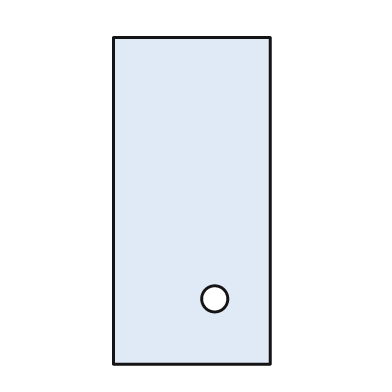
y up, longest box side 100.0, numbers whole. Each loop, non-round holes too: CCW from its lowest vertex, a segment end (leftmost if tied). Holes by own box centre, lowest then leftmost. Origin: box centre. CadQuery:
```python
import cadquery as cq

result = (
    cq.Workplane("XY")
    .moveTo(-24.0, -50.0)
    .lineTo(24.0, -50.0)
    .lineTo(24.0, 50.0)
    .lineTo(-24.0, 50.0)
    .close()
    .moveTo(7.0, -30.0)
    .circle(4.0)
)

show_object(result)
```